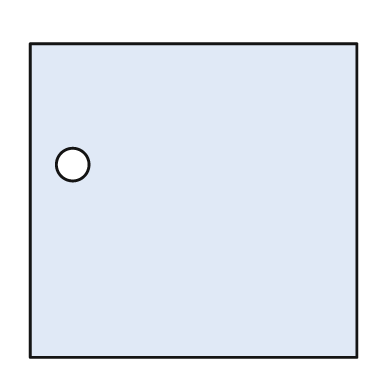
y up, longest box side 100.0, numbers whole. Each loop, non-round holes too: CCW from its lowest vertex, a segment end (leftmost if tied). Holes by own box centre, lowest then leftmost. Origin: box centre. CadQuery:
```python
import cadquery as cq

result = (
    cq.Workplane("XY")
    .moveTo(-50.0, -48.0)
    .lineTo(50.0, -48.0)
    .lineTo(50.0, 48.0)
    .lineTo(-50.0, 48.0)
    .close()
    .moveTo(-37.0, 11.0)
    .circle(5.0)
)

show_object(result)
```